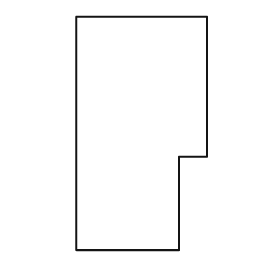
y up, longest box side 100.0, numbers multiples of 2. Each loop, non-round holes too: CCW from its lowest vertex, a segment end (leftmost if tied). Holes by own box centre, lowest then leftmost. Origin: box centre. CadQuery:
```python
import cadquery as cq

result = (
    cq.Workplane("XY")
    .moveTo(-28.0, -50.0)
    .lineTo(16.0, -50.0)
    .lineTo(16.0, -10.0)
    .lineTo(28.0, -10.0)
    .lineTo(28.0, 50.0)
    .lineTo(-28.0, 50.0)
    .close()
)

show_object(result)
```